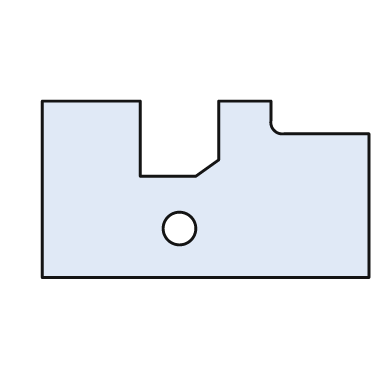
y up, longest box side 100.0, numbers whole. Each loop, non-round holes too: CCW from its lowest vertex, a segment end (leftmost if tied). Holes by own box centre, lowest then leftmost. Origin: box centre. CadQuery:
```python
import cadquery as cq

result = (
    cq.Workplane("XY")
    .moveTo(-50.0, -27.0)
    .lineTo(50.0, -27.0)
    .lineTo(50.0, 17.0)
    .lineTo(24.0, 17.0)
    .threePointArc((21.0, 18.0), (20.0, 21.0))
    .lineTo(20.0, 27.0)
    .lineTo(4.0, 27.0)
    .lineTo(4.0, 9.0)
    .lineTo(-3.0, 4.0)
    .lineTo(-20.0, 4.0)
    .lineTo(-20.0, 27.0)
    .lineTo(-50.0, 27.0)
    .close()
    .moveTo(-8.0, -12.0)
    .circle(5.0)
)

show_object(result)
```